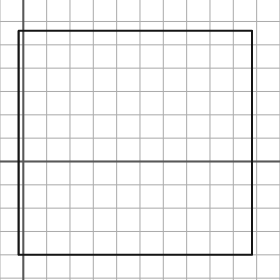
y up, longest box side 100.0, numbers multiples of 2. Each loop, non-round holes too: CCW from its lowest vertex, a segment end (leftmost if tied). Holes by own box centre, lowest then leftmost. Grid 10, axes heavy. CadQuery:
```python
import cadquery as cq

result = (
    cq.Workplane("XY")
    .moveTo(-2.0, -40.0)
    .lineTo(98.0, -40.0)
    .lineTo(98.0, 56.0)
    .lineTo(-2.0, 56.0)
    .close()
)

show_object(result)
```